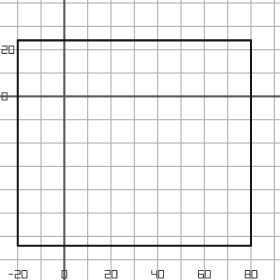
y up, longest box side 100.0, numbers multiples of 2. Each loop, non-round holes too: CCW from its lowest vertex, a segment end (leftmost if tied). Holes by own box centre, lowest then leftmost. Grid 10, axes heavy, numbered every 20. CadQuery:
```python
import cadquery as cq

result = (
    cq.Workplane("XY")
    .moveTo(-20.0, -64.0)
    .lineTo(80.0, -64.0)
    .lineTo(80.0, 24.0)
    .lineTo(-20.0, 24.0)
    .close()
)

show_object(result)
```